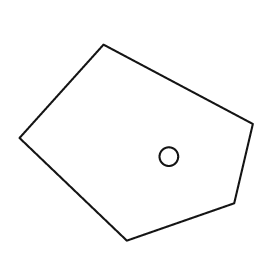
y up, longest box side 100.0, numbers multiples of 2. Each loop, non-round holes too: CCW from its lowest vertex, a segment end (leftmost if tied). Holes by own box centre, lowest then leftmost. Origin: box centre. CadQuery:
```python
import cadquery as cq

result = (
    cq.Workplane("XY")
    .moveTo(-4.0, -42.0)
    .lineTo(42.0, -26.0)
    .lineTo(50.0, 8.0)
    .lineTo(-14.0, 42.0)
    .lineTo(-50.0, 2.0)
    .close()
    .moveTo(14.0, -6.0)
    .circle(4.0)
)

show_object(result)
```